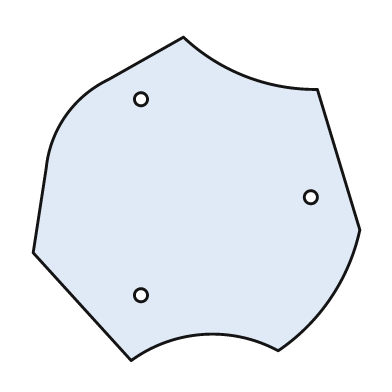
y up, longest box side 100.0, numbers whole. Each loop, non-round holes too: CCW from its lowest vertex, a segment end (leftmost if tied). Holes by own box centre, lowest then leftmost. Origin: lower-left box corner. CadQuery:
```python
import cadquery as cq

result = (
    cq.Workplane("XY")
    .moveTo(30.0, 0.0)
    .threePointArc((52.0, 8.0), (75.0, 3.0))
    .threePointArc((91.0, 19.0), (100.0, 40.0))
    .lineTo(87.0, 83.0)
    .threePointArc((65.0, 87.0), (46.0, 99.0))
    .lineTo(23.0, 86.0)
    .threePointArc((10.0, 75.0), (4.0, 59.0))
    .lineTo(0.0, 33.0)
    .close()
    .moveTo(33.0, 20.0)
    .circle(2.0)
    .moveTo(85.0, 50.0)
    .circle(2.0)
    .moveTo(33.0, 80.0)
    .circle(2.0)
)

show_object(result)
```